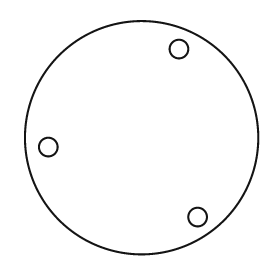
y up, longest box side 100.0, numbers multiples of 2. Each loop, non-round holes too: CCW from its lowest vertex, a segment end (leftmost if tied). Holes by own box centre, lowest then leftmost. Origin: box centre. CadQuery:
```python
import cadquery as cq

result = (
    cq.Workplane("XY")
    .moveTo(0.0, 0.0)
    .circle(50.0)
    .moveTo(24.0, -34.0)
    .circle(4.0)
    .moveTo(-40.0, -4.0)
    .circle(4.0)
    .moveTo(16.0, 38.0)
    .circle(4.0)
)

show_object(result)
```